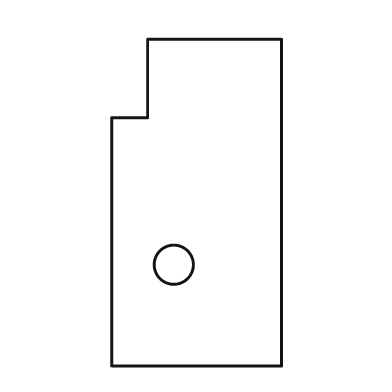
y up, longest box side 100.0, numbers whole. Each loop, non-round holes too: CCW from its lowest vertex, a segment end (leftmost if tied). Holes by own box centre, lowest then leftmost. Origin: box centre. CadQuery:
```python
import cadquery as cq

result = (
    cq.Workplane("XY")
    .moveTo(-26.0, -50.0)
    .lineTo(26.0, -50.0)
    .lineTo(26.0, 50.0)
    .lineTo(-15.0, 50.0)
    .lineTo(-15.0, 26.0)
    .lineTo(-26.0, 26.0)
    .close()
    .moveTo(-7.0, -19.0)
    .circle(6.0)
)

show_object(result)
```